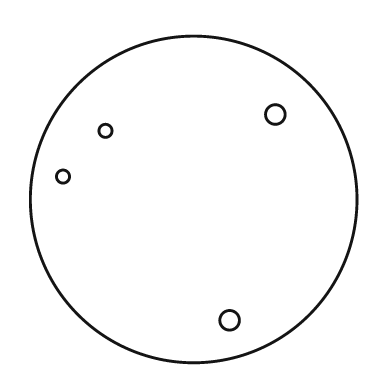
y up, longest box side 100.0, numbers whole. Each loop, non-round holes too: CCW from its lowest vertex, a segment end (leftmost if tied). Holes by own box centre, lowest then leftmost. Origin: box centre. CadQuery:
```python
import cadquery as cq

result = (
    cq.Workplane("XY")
    .moveTo(0.0, 0.0)
    .circle(50.0)
    .moveTo(11.0, -37.0)
    .circle(3.0)
    .moveTo(-40.0, 7.0)
    .circle(2.0)
    .moveTo(-27.0, 21.0)
    .circle(2.0)
    .moveTo(25.0, 26.0)
    .circle(3.0)
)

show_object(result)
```